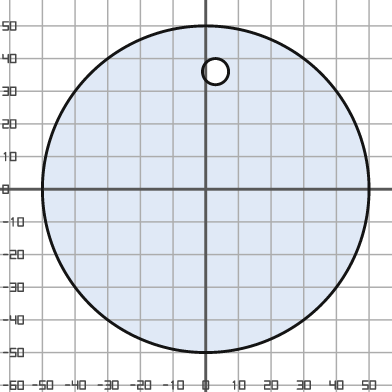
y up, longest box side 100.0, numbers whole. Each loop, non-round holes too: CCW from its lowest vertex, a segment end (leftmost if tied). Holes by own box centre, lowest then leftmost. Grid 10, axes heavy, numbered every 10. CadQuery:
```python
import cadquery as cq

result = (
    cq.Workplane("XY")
    .moveTo(0.0, 0.0)
    .circle(50.0)
    .moveTo(3.0, 36.0)
    .circle(4.0)
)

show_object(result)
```